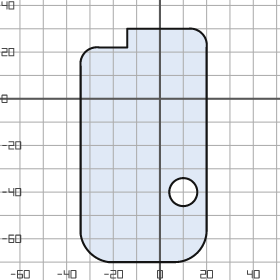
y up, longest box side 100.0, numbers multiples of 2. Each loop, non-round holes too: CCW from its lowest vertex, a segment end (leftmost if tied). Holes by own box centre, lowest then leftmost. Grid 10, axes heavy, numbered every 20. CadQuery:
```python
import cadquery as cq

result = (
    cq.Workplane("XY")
    .moveTo(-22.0, -70.0)
    .lineTo(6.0, -70.0)
    .threePointArc((16.0, -66.0), (20.0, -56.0))
    .lineTo(20.0, 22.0)
    .threePointArc((18.0, 28.0), (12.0, 30.0))
    .lineTo(-14.0, 30.0)
    .lineTo(-14.0, 22.0)
    .lineTo(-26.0, 22.0)
    .threePointArc((-32.0, 20.0), (-34.0, 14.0))
    .lineTo(-34.0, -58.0)
    .threePointArc((-30.0, -66.0), (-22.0, -70.0))
    .close()
    .moveTo(10.0, -40.0)
    .circle(6.0)
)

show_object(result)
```